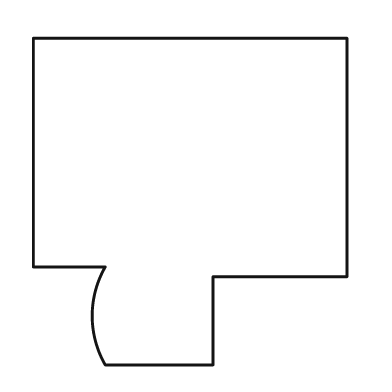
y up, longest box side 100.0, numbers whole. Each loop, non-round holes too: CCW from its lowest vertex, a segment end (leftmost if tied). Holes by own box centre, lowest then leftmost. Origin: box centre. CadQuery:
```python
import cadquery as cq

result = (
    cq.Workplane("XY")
    .moveTo(-26.0, -50.0)
    .lineTo(7.0, -50.0)
    .lineTo(7.0, -23.0)
    .lineTo(48.0, -23.0)
    .lineTo(48.0, 50.0)
    .lineTo(-48.0, 50.0)
    .lineTo(-48.0, -20.0)
    .lineTo(-26.0, -20.0)
    .threePointArc((-30.0, -35.0), (-26.0, -50.0))
    .close()
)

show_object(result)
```